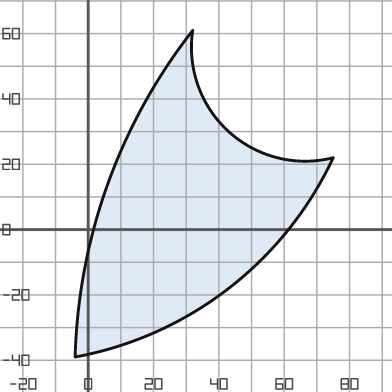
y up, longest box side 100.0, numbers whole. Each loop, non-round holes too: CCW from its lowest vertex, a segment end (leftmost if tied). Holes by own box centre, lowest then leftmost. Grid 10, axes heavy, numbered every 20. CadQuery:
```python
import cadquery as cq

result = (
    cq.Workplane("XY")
    .moveTo(-4.0, -39.0)
    .threePointArc((43.0, -18.0), (75.0, 22.0))
    .threePointArc((43.0, 30.0), (32.0, 61.0))
    .threePointArc((6.0, 14.0), (-4.0, -39.0))
    .close()
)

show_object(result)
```